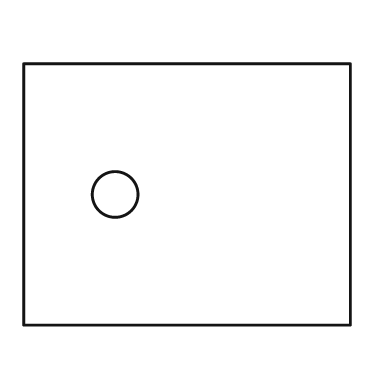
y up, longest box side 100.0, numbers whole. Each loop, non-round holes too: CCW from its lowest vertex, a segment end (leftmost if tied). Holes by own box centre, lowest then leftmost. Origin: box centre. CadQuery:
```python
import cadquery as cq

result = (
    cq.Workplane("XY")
    .moveTo(-50.0, -40.0)
    .lineTo(50.0, -40.0)
    .lineTo(50.0, 40.0)
    .lineTo(-50.0, 40.0)
    .close()
    .moveTo(-22.0, 0.0)
    .circle(7.0)
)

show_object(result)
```